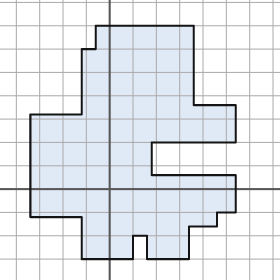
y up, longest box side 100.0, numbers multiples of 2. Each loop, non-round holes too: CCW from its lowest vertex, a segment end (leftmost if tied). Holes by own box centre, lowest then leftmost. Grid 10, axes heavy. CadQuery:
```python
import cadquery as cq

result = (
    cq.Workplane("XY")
    .moveTo(-12.0, -30.0)
    .lineTo(10.0, -30.0)
    .lineTo(10.0, -20.0)
    .lineTo(16.0, -20.0)
    .lineTo(16.0, -30.0)
    .lineTo(34.0, -30.0)
    .lineTo(34.0, -16.0)
    .lineTo(46.0, -16.0)
    .lineTo(46.0, -10.0)
    .lineTo(54.0, -10.0)
    .lineTo(54.0, 6.0)
    .lineTo(18.0, 6.0)
    .lineTo(18.0, 20.0)
    .lineTo(54.0, 20.0)
    .lineTo(54.0, 36.0)
    .lineTo(36.0, 36.0)
    .lineTo(36.0, 70.0)
    .lineTo(-6.0, 70.0)
    .lineTo(-6.0, 60.0)
    .lineTo(-12.0, 60.0)
    .lineTo(-12.0, 32.0)
    .lineTo(-34.0, 32.0)
    .lineTo(-34.0, -12.0)
    .lineTo(-12.0, -12.0)
    .close()
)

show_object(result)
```